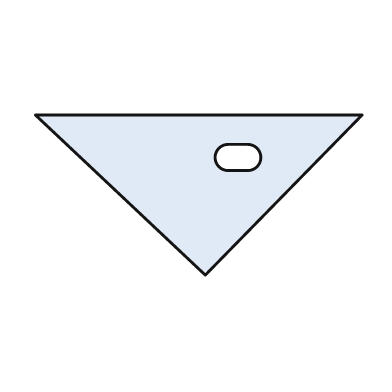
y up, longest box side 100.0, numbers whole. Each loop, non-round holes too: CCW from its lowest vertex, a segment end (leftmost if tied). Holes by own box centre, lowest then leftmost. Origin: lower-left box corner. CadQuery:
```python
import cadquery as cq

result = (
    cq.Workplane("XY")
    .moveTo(52.0, 0.0)
    .lineTo(100.0, 49.0)
    .lineTo(0.0, 49.0)
    .close()
    .moveTo(59.0, 32.0)
    .lineTo(65.0, 32.0)
    .threePointArc((69.0, 36.0), (65.0, 40.0))
    .lineTo(59.0, 40.0)
    .threePointArc((55.0, 36.0), (59.0, 32.0))
    .close()
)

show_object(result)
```